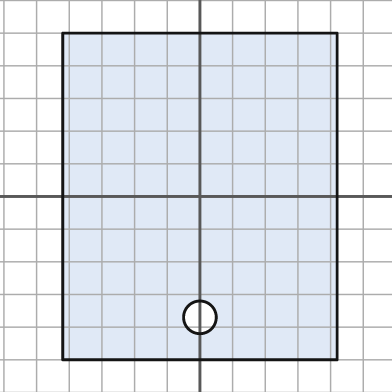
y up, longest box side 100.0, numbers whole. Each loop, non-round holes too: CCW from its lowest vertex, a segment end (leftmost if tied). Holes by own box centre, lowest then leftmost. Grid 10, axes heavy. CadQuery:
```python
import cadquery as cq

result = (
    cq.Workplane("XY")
    .moveTo(-42.0, -50.0)
    .lineTo(42.0, -50.0)
    .lineTo(42.0, 50.0)
    .lineTo(-42.0, 50.0)
    .close()
    .moveTo(0.0, -37.0)
    .circle(5.0)
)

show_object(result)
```